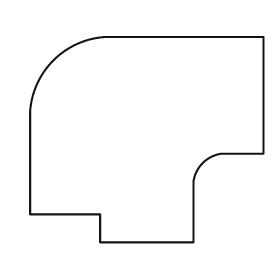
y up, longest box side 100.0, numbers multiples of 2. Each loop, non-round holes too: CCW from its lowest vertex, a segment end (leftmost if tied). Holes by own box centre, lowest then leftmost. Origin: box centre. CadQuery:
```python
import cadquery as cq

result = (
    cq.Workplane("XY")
    .moveTo(-20.0, -44.0)
    .lineTo(20.0, -44.0)
    .lineTo(20.0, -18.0)
    .threePointArc((24.0, -10.0), (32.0, -6.0))
    .lineTo(50.0, -6.0)
    .lineTo(50.0, 44.0)
    .lineTo(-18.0, 44.0)
    .threePointArc((-40.0, 34.0), (-50.0, 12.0))
    .lineTo(-50.0, -32.0)
    .lineTo(-20.0, -32.0)
    .close()
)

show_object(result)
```